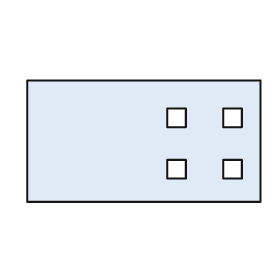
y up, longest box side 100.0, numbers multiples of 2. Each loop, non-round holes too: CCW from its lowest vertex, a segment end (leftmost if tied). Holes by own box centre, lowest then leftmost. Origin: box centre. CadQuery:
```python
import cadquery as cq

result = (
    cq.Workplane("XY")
    .moveTo(-50.0, -26.0)
    .lineTo(50.0, -26.0)
    .lineTo(50.0, 26.0)
    .lineTo(-50.0, 26.0)
    .close()
    .moveTo(10.0, -16.0)
    .lineTo(18.0, -16.0)
    .lineTo(18.0, -8.0)
    .lineTo(10.0, -8.0)
    .close()
    .moveTo(34.0, -16.0)
    .lineTo(42.0, -16.0)
    .lineTo(42.0, -8.0)
    .lineTo(34.0, -8.0)
    .close()
    .moveTo(10.0, 6.0)
    .lineTo(18.0, 6.0)
    .lineTo(18.0, 14.0)
    .lineTo(10.0, 14.0)
    .close()
    .moveTo(34.0, 6.0)
    .lineTo(42.0, 6.0)
    .lineTo(42.0, 14.0)
    .lineTo(34.0, 14.0)
    .close()
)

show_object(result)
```